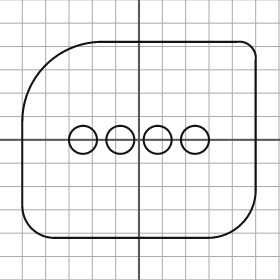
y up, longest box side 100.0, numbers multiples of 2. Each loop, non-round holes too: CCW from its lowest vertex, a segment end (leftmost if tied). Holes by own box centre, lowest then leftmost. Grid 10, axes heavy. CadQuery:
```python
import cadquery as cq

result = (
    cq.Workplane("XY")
    .moveTo(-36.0, -42.0)
    .lineTo(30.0, -42.0)
    .threePointArc((44.0, -36.0), (50.0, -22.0))
    .lineTo(50.0, 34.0)
    .threePointArc((48.0, 40.0), (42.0, 42.0))
    .lineTo(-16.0, 42.0)
    .threePointArc((-40.0, 32.0), (-50.0, 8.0))
    .lineTo(-50.0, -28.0)
    .threePointArc((-46.0, -38.0), (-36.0, -42.0))
    .close()
    .moveTo(-24.0, 0.0)
    .circle(6.0)
    .moveTo(-8.0, 0.0)
    .circle(6.0)
    .moveTo(8.0, 0.0)
    .circle(6.0)
    .moveTo(24.0, 0.0)
    .circle(6.0)
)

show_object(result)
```